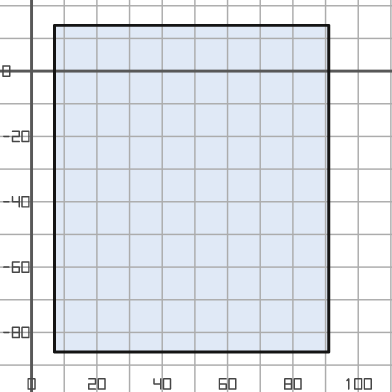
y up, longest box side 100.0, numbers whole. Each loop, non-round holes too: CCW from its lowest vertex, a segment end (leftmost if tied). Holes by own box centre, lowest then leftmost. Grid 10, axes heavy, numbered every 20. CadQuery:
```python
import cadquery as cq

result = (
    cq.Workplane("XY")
    .moveTo(7.0, -86.0)
    .lineTo(91.0, -86.0)
    .lineTo(91.0, 14.0)
    .lineTo(7.0, 14.0)
    .close()
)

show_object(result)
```